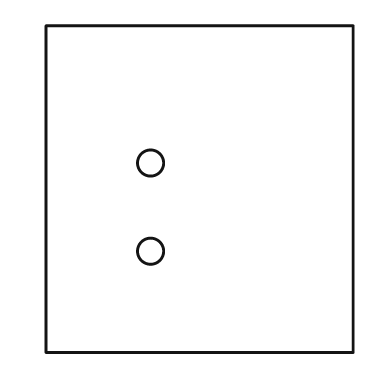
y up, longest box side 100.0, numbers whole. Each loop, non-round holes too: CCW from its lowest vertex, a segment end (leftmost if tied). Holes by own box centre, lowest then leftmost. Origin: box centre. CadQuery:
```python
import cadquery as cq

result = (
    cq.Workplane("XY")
    .moveTo(-47.0, -50.0)
    .lineTo(47.0, -50.0)
    .lineTo(47.0, 50.0)
    .lineTo(-47.0, 50.0)
    .close()
    .moveTo(-15.0, -19.0)
    .circle(4.0)
    .moveTo(-15.0, 8.0)
    .circle(4.0)
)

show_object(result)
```